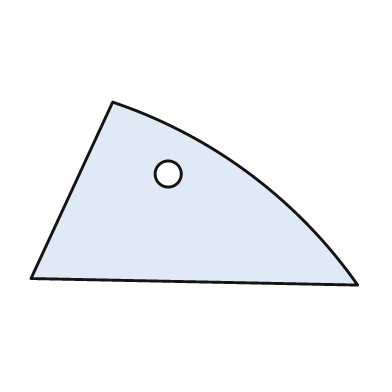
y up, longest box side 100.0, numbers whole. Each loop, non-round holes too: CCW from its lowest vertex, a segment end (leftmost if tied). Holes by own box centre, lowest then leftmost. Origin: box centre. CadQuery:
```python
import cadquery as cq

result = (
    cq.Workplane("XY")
    .moveTo(50.0, -28.0)
    .threePointArc((17.0, 6.0), (-25.0, 28.0))
    .lineTo(-50.0, -26.0)
    .close()
    .moveTo(-8.0, 6.0)
    .circle(4.0)
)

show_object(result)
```